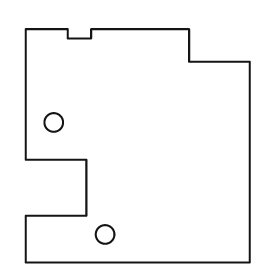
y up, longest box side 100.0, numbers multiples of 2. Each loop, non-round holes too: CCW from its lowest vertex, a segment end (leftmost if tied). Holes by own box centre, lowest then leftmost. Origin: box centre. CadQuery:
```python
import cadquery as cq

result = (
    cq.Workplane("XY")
    .moveTo(-48.0, -50.0)
    .lineTo(48.0, -50.0)
    .lineTo(48.0, 36.0)
    .lineTo(22.0, 36.0)
    .lineTo(22.0, 50.0)
    .lineTo(-20.0, 50.0)
    .lineTo(-20.0, 46.0)
    .lineTo(-30.0, 46.0)
    .lineTo(-30.0, 50.0)
    .lineTo(-48.0, 50.0)
    .lineTo(-48.0, -6.0)
    .lineTo(-22.0, -6.0)
    .lineTo(-22.0, -30.0)
    .lineTo(-48.0, -30.0)
    .close()
    .moveTo(-14.0, -38.0)
    .circle(4.0)
    .moveTo(-36.0, 10.0)
    .circle(4.0)
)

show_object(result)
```